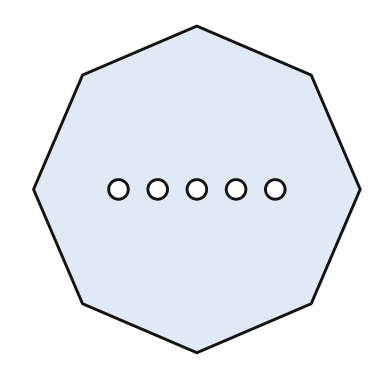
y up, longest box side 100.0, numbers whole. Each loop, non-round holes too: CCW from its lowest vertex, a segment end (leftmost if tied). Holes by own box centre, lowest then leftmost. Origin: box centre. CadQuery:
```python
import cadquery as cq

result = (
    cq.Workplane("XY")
    .moveTo(0.0, -50.0)
    .lineTo(35.0, -35.0)
    .lineTo(50.0, 0.0)
    .lineTo(35.0, 35.0)
    .lineTo(0.0, 50.0)
    .lineTo(-35.0, 35.0)
    .lineTo(-50.0, 0.0)
    .lineTo(-35.0, -35.0)
    .close()
    .moveTo(-24.0, 0.0)
    .circle(3.0)
    .moveTo(-12.0, 0.0)
    .circle(3.0)
    .moveTo(0.0, 0.0)
    .circle(3.0)
    .moveTo(12.0, 0.0)
    .circle(3.0)
    .moveTo(24.0, 0.0)
    .circle(3.0)
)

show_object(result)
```